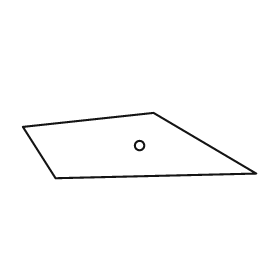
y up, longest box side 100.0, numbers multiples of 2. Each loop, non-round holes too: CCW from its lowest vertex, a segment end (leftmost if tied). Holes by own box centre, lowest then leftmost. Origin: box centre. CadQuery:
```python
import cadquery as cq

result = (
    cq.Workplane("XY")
    .moveTo(-36.0, -14.0)
    .lineTo(50.0, -12.0)
    .lineTo(6.0, 14.0)
    .lineTo(-50.0, 8.0)
    .close()
    .moveTo(0.0, 0.0)
    .circle(2.0)
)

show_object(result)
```